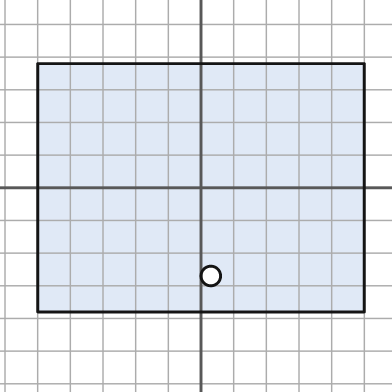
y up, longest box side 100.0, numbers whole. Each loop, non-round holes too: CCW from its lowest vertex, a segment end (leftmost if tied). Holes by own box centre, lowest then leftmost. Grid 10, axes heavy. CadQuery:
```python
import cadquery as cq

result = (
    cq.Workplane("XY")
    .moveTo(-50.0, -38.0)
    .lineTo(50.0, -38.0)
    .lineTo(50.0, 38.0)
    .lineTo(-50.0, 38.0)
    .close()
    .moveTo(3.0, -27.0)
    .circle(3.0)
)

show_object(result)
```